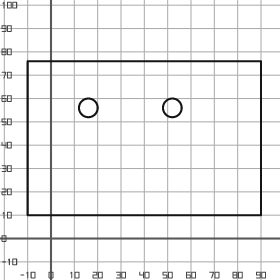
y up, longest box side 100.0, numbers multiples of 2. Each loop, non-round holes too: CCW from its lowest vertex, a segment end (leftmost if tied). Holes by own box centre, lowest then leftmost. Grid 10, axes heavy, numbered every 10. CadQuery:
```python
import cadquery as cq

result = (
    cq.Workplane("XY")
    .moveTo(-10.0, 10.0)
    .lineTo(90.0, 10.0)
    .lineTo(90.0, 76.0)
    .lineTo(-10.0, 76.0)
    .close()
    .moveTo(16.0, 56.0)
    .circle(4.0)
    .moveTo(52.0, 56.0)
    .circle(4.0)
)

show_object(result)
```